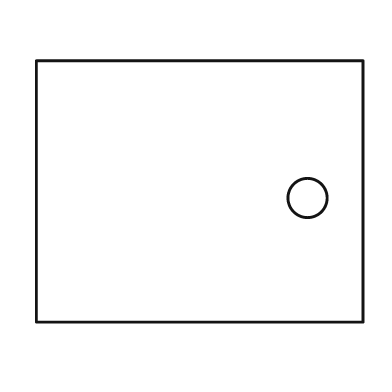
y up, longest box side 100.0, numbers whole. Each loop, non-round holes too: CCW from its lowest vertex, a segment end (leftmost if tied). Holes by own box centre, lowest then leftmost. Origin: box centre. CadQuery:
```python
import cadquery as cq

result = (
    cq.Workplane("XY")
    .moveTo(-50.0, -40.0)
    .lineTo(50.0, -40.0)
    .lineTo(50.0, 40.0)
    .lineTo(-50.0, 40.0)
    .close()
    .moveTo(33.0, -2.0)
    .circle(6.0)
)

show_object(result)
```